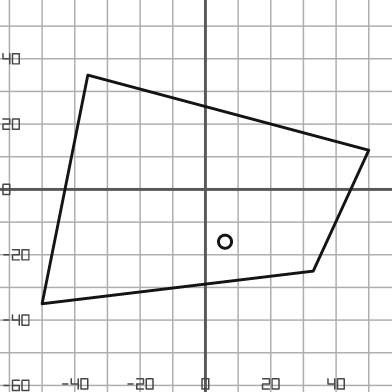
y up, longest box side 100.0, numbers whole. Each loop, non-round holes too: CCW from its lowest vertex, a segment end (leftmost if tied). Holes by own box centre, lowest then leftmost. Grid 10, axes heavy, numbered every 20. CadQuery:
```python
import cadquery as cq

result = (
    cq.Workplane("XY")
    .moveTo(-50.0, -35.0)
    .lineTo(33.0, -25.0)
    .lineTo(50.0, 12.0)
    .lineTo(-36.0, 35.0)
    .close()
    .moveTo(6.0, -16.0)
    .circle(2.0)
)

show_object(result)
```